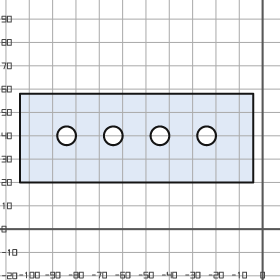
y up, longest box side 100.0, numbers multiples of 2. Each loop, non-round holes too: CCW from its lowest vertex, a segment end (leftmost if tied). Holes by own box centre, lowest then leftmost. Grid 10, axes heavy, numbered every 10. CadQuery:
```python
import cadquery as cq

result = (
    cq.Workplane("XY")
    .moveTo(-104.0, 20.0)
    .lineTo(-4.0, 20.0)
    .lineTo(-4.0, 58.0)
    .lineTo(-104.0, 58.0)
    .close()
    .moveTo(-84.0, 40.0)
    .circle(4.0)
    .moveTo(-64.0, 40.0)
    .circle(4.0)
    .moveTo(-44.0, 40.0)
    .circle(4.0)
    .moveTo(-24.0, 40.0)
    .circle(4.0)
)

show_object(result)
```